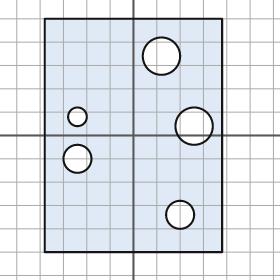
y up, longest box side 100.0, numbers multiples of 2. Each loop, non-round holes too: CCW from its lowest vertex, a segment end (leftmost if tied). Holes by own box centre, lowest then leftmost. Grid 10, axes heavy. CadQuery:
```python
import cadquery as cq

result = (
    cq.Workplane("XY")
    .moveTo(-38.0, -50.0)
    .lineTo(38.0, -50.0)
    .lineTo(38.0, 50.0)
    .lineTo(-38.0, 50.0)
    .close()
    .moveTo(20.0, -34.0)
    .circle(6.0)
    .moveTo(-24.0, -10.0)
    .circle(6.0)
    .moveTo(26.0, 4.0)
    .circle(8.0)
    .moveTo(-24.0, 8.0)
    .circle(4.0)
    .moveTo(12.0, 34.0)
    .circle(8.0)
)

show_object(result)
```